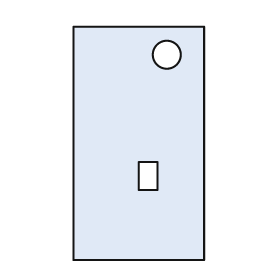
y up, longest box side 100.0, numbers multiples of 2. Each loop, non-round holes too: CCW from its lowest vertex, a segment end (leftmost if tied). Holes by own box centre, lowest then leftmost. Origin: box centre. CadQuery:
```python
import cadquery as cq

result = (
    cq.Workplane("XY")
    .moveTo(-28.0, -50.0)
    .lineTo(28.0, -50.0)
    .lineTo(28.0, 50.0)
    .lineTo(-28.0, 50.0)
    .close()
    .moveTo(0.0, -20.0)
    .lineTo(8.0, -20.0)
    .lineTo(8.0, -8.0)
    .lineTo(0.0, -8.0)
    .close()
    .moveTo(12.0, 38.0)
    .circle(6.0)
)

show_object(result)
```